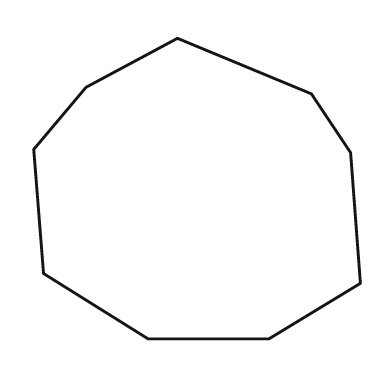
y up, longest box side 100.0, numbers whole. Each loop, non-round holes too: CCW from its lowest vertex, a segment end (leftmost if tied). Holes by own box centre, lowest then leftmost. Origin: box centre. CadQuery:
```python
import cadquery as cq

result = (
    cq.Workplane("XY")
    .moveTo(-15.0, -46.0)
    .lineTo(22.0, -46.0)
    .lineTo(50.0, -29.0)
    .lineTo(47.0, 11.0)
    .lineTo(35.0, 29.0)
    .lineTo(-6.0, 46.0)
    .lineTo(-34.0, 31.0)
    .lineTo(-50.0, 12.0)
    .lineTo(-47.0, -26.0)
    .close()
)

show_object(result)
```